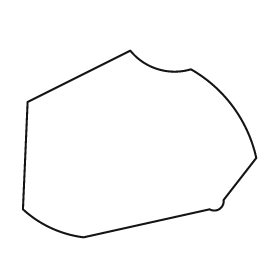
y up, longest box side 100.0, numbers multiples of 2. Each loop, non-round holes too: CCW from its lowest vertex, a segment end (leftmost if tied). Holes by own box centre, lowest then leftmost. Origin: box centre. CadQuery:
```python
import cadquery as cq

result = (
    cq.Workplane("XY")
    .moveTo(-24.0, -40.0)
    .lineTo(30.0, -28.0)
    .threePointArc((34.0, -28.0), (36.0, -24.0))
    .lineTo(50.0, -6.0)
    .threePointArc((40.0, 16.0), (22.0, 32.0))
    .threePointArc((8.0, 32.0), (-4.0, 40.0))
    .lineTo(-48.0, 18.0)
    .lineTo(-50.0, -28.0)
    .threePointArc((-38.0, -36.0), (-24.0, -40.0))
    .close()
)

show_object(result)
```